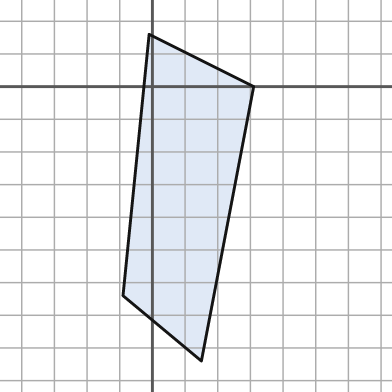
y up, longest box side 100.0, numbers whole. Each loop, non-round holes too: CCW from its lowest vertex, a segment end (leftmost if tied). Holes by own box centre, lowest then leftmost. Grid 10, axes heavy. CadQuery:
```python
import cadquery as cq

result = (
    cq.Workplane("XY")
    .moveTo(15.0, -84.0)
    .lineTo(31.0, 0.0)
    .lineTo(-1.0, 16.0)
    .lineTo(-9.0, -64.0)
    .close()
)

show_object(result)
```